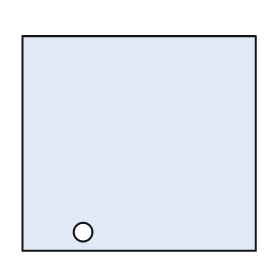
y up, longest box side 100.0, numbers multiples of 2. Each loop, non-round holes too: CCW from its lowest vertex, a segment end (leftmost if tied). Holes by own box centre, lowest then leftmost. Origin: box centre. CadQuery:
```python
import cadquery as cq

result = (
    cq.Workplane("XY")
    .moveTo(-50.0, -46.0)
    .lineTo(50.0, -46.0)
    .lineTo(50.0, 46.0)
    .lineTo(-50.0, 46.0)
    .close()
    .moveTo(-24.0, -38.0)
    .circle(4.0)
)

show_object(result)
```